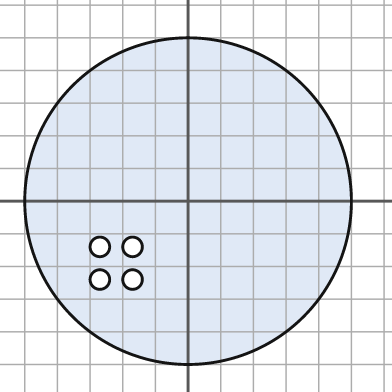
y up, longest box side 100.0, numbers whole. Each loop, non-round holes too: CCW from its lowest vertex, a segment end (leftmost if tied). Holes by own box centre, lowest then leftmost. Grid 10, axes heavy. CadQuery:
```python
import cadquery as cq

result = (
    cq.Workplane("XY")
    .moveTo(0.0, 0.0)
    .circle(50.0)
    .moveTo(-27.0, -24.0)
    .circle(3.0)
    .moveTo(-17.0, -24.0)
    .circle(3.0)
    .moveTo(-27.0, -14.0)
    .circle(3.0)
    .moveTo(-17.0, -14.0)
    .circle(3.0)
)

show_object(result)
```